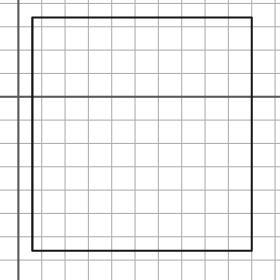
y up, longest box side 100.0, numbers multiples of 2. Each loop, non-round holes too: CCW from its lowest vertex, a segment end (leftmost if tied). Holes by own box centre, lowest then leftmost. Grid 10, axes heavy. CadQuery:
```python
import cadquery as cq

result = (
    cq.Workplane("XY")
    .moveTo(6.0, -66.0)
    .lineTo(100.0, -66.0)
    .lineTo(100.0, 34.0)
    .lineTo(6.0, 34.0)
    .close()
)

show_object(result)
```